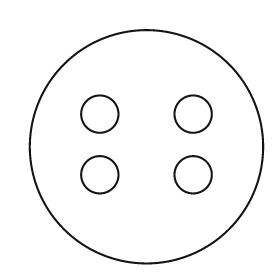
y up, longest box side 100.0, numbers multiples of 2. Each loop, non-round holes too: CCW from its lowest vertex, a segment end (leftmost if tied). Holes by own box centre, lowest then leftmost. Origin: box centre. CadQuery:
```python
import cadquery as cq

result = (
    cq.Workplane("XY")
    .moveTo(0.0, 0.0)
    .circle(50.0)
    .moveTo(-20.0, -12.0)
    .circle(8.0)
    .moveTo(20.0, -12.0)
    .circle(8.0)
    .moveTo(-20.0, 14.0)
    .circle(8.0)
    .moveTo(20.0, 14.0)
    .circle(8.0)
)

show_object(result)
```